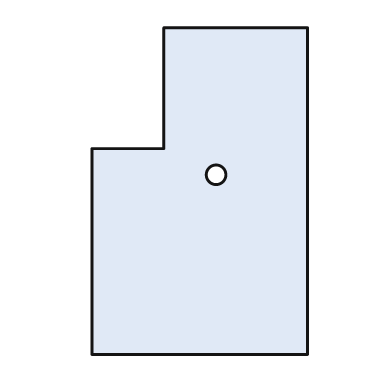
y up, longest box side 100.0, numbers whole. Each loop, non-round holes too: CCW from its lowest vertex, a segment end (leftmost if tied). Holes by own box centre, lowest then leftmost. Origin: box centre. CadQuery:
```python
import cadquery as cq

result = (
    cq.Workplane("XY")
    .moveTo(-33.0, -50.0)
    .lineTo(33.0, -50.0)
    .lineTo(33.0, 50.0)
    .lineTo(-11.0, 50.0)
    .lineTo(-11.0, 13.0)
    .lineTo(-33.0, 13.0)
    .close()
    .moveTo(5.0, 5.0)
    .circle(3.0)
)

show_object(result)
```